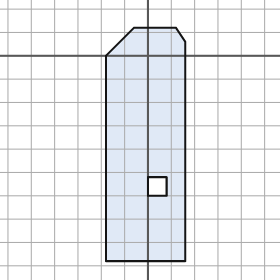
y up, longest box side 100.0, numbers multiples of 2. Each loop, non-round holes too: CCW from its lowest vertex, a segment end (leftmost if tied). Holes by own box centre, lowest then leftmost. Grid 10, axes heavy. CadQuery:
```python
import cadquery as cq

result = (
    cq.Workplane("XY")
    .moveTo(-18.0, -88.0)
    .lineTo(16.0, -88.0)
    .lineTo(16.0, 6.0)
    .lineTo(12.0, 12.0)
    .lineTo(-6.0, 12.0)
    .lineTo(-18.0, 0.0)
    .close()
    .moveTo(0.0, -60.0)
    .lineTo(8.0, -60.0)
    .lineTo(8.0, -52.0)
    .lineTo(0.0, -52.0)
    .close()
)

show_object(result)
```